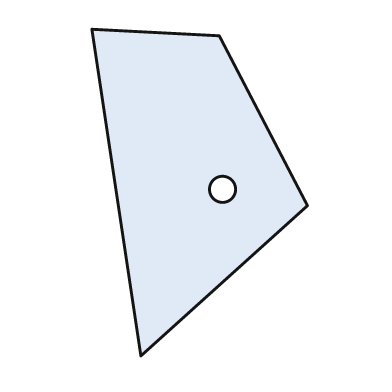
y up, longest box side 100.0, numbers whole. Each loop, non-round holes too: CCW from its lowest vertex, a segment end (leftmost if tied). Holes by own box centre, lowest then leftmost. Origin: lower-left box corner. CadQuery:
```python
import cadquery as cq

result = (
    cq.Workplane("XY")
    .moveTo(15.0, 0.0)
    .lineTo(66.0, 46.0)
    .lineTo(39.0, 98.0)
    .lineTo(0.0, 100.0)
    .close()
    .moveTo(40.0, 51.0)
    .circle(4.0)
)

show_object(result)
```